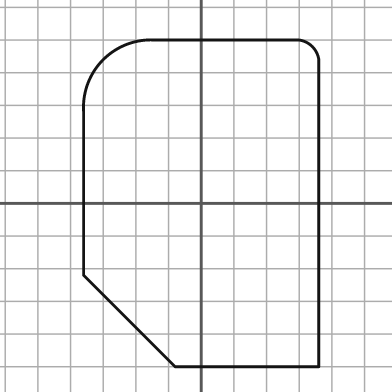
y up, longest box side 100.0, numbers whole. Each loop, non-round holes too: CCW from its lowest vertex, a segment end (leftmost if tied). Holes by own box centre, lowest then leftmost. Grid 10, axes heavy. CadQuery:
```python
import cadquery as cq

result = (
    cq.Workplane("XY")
    .moveTo(-8.0, -50.0)
    .lineTo(36.0, -50.0)
    .lineTo(36.0, 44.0)
    .threePointArc((34.0, 48.0), (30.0, 50.0))
    .lineTo(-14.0, 50.0)
    .threePointArc((-30.0, 44.0), (-36.0, 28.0))
    .lineTo(-36.0, -22.0)
    .close()
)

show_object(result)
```